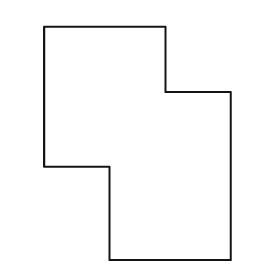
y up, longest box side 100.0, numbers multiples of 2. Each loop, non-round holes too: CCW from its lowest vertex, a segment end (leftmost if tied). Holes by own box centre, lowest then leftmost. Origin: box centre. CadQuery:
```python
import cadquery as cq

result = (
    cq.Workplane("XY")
    .moveTo(-12.0, -50.0)
    .lineTo(40.0, -50.0)
    .lineTo(40.0, 22.0)
    .lineTo(12.0, 22.0)
    .lineTo(12.0, 50.0)
    .lineTo(-40.0, 50.0)
    .lineTo(-40.0, -10.0)
    .lineTo(-12.0, -10.0)
    .close()
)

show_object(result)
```